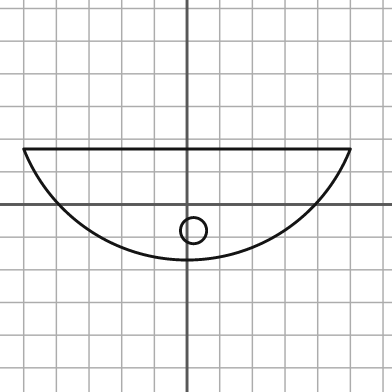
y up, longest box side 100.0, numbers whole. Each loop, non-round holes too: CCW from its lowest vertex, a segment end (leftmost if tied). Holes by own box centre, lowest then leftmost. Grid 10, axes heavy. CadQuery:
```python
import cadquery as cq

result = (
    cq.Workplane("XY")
    .moveTo(-50.0, 17.0)
    .threePointArc((0.0, -17.0), (50.0, 17.0))
    .close()
    .moveTo(2.0, -8.0)
    .circle(4.0)
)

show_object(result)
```